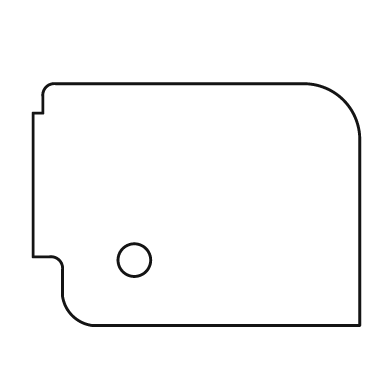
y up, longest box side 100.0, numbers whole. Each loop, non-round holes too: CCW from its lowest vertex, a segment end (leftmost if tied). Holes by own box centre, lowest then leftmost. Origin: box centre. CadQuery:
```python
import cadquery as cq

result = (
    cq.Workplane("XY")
    .moveTo(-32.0, -37.0)
    .lineTo(50.0, -37.0)
    .lineTo(50.0, 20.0)
    .threePointArc((45.0, 32.0), (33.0, 37.0))
    .lineTo(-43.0, 37.0)
    .threePointArc((-46.0, 36.0), (-47.0, 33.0))
    .lineTo(-47.0, 28.0)
    .lineTo(-50.0, 28.0)
    .lineTo(-50.0, -16.0)
    .lineTo(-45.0, -16.0)
    .threePointArc((-42.0, -17.0), (-41.0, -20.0))
    .lineTo(-41.0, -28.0)
    .threePointArc((-38.0, -34.0), (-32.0, -37.0))
    .close()
    .moveTo(-19.0, -17.0)
    .circle(5.0)
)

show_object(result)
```